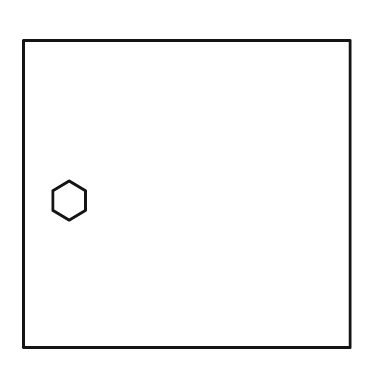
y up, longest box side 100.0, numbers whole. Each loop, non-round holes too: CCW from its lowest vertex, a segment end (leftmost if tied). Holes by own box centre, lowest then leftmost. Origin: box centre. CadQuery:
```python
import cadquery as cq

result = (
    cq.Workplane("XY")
    .moveTo(-50.0, -47.0)
    .lineTo(50.0, -47.0)
    .lineTo(50.0, 47.0)
    .lineTo(-50.0, 47.0)
    .close()
    .moveTo(-36.0, -8.0)
    .lineTo(-31.0, -5.0)
    .lineTo(-31.0, 1.0)
    .lineTo(-36.0, 4.0)
    .lineTo(-41.0, 1.0)
    .lineTo(-41.0, -5.0)
    .close()
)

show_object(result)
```